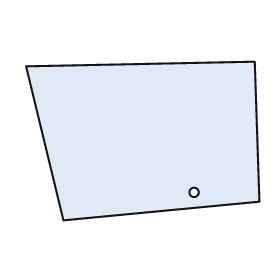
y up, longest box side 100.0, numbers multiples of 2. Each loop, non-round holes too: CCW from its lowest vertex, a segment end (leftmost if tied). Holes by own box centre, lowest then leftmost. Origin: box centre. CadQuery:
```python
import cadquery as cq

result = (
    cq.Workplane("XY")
    .moveTo(-34.0, -34.0)
    .lineTo(50.0, -26.0)
    .lineTo(48.0, 34.0)
    .lineTo(-50.0, 32.0)
    .close()
    .moveTo(22.0, -22.0)
    .circle(2.0)
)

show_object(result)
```